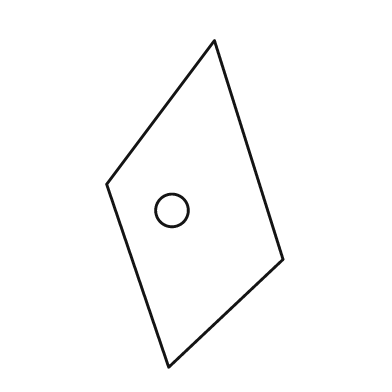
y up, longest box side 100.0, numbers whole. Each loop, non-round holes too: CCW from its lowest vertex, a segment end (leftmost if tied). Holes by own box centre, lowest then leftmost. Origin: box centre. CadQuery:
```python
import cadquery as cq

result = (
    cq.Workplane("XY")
    .moveTo(-8.0, -50.0)
    .lineTo(27.0, -17.0)
    .lineTo(6.0, 50.0)
    .lineTo(-27.0, 6.0)
    .close()
    .moveTo(-7.0, -2.0)
    .circle(5.0)
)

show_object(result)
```